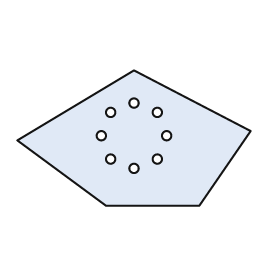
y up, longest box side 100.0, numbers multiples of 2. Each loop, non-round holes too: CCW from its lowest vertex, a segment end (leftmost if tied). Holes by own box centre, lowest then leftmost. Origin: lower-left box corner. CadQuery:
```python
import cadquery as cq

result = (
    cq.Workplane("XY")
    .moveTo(38.0, 0.0)
    .lineTo(78.0, 0.0)
    .lineTo(100.0, 32.0)
    .lineTo(50.0, 58.0)
    .lineTo(0.0, 28.0)
    .close()
    .moveTo(50.0, 16.0)
    .circle(2.0)
    .moveTo(40.0, 20.0)
    .circle(2.0)
    .moveTo(60.0, 20.0)
    .circle(2.0)
    .moveTo(36.0, 30.0)
    .circle(2.0)
    .moveTo(64.0, 30.0)
    .circle(2.0)
    .moveTo(40.0, 40.0)
    .circle(2.0)
    .moveTo(60.0, 40.0)
    .circle(2.0)
    .moveTo(50.0, 44.0)
    .circle(2.0)
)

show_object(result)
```